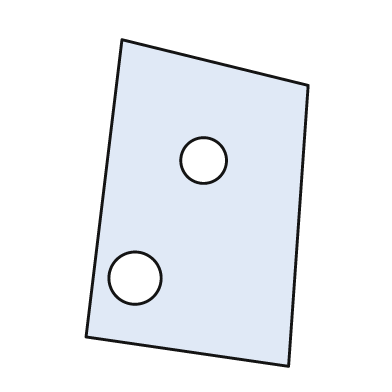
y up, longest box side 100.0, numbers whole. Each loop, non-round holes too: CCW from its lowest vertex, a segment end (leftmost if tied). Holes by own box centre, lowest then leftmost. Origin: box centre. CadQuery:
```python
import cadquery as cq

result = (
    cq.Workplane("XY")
    .moveTo(28.0, -50.0)
    .lineTo(34.0, 36.0)
    .lineTo(-23.0, 50.0)
    .lineTo(-34.0, -41.0)
    .close()
    .moveTo(-19.0, -23.0)
    .circle(8.0)
    .moveTo(2.0, 13.0)
    .circle(7.0)
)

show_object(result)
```